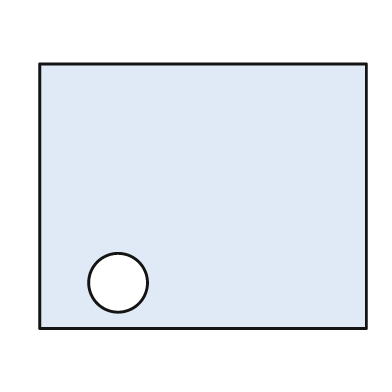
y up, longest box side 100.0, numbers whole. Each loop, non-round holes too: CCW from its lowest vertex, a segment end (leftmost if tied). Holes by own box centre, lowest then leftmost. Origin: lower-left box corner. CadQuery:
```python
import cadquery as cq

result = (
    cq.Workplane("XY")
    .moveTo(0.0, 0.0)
    .lineTo(100.0, 0.0)
    .lineTo(100.0, 81.0)
    .lineTo(0.0, 81.0)
    .close()
    .moveTo(24.0, 14.0)
    .circle(9.0)
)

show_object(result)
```